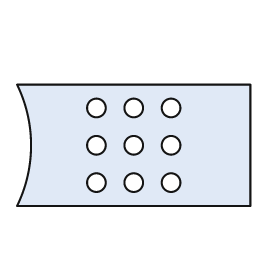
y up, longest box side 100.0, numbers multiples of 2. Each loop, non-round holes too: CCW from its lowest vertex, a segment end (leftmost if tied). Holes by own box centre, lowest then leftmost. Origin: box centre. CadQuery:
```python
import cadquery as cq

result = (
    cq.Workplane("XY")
    .moveTo(-50.0, -26.0)
    .lineTo(50.0, -26.0)
    .lineTo(50.0, 26.0)
    .lineTo(-50.0, 26.0)
    .threePointArc((-44.0, 0.0), (-50.0, -26.0))
    .close()
    .moveTo(-16.0, -16.0)
    .circle(4.0)
    .moveTo(0.0, -16.0)
    .circle(4.0)
    .moveTo(16.0, -16.0)
    .circle(4.0)
    .moveTo(-16.0, 0.0)
    .circle(4.0)
    .moveTo(0.0, 0.0)
    .circle(4.0)
    .moveTo(16.0, 0.0)
    .circle(4.0)
    .moveTo(-16.0, 16.0)
    .circle(4.0)
    .moveTo(0.0, 16.0)
    .circle(4.0)
    .moveTo(16.0, 16.0)
    .circle(4.0)
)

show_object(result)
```